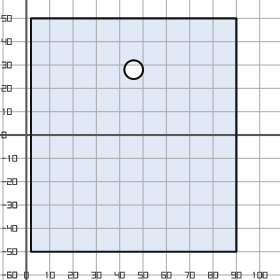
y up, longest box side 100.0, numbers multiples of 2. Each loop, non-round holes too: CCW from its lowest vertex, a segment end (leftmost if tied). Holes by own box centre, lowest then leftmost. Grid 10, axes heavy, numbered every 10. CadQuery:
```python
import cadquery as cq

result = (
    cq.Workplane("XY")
    .moveTo(2.0, -50.0)
    .lineTo(90.0, -50.0)
    .lineTo(90.0, 50.0)
    .lineTo(2.0, 50.0)
    .close()
    .moveTo(46.0, 28.0)
    .circle(4.0)
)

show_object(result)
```